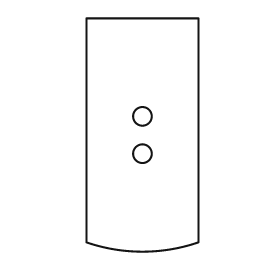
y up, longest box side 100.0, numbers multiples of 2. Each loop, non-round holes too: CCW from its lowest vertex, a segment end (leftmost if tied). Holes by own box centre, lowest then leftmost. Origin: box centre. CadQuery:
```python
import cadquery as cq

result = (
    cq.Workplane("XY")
    .moveTo(-24.0, -46.0)
    .threePointArc((0.0, -50.0), (24.0, -46.0))
    .lineTo(24.0, 50.0)
    .lineTo(-24.0, 50.0)
    .close()
    .moveTo(0.0, -8.0)
    .circle(4.0)
    .moveTo(0.0, 8.0)
    .circle(4.0)
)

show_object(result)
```